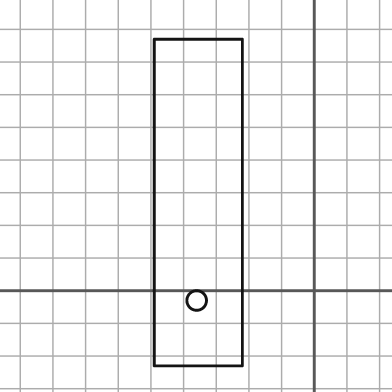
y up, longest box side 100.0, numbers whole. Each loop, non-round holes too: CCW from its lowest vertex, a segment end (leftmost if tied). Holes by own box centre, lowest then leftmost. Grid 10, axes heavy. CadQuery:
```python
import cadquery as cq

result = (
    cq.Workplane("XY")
    .moveTo(-49.0, -23.0)
    .lineTo(-22.0, -23.0)
    .lineTo(-22.0, 77.0)
    .lineTo(-49.0, 77.0)
    .close()
    .moveTo(-36.0, -3.0)
    .circle(3.0)
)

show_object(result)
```